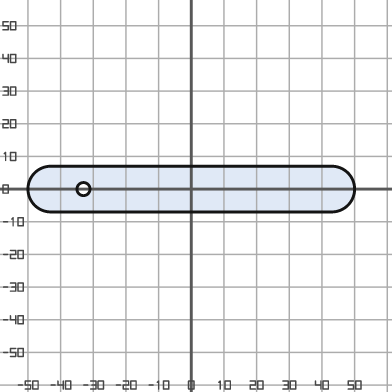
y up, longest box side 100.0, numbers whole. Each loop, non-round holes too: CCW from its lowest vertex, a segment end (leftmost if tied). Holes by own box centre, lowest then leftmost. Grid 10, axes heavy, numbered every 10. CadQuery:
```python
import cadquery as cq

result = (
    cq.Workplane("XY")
    .moveTo(-43.0, -7.0)
    .lineTo(43.0, -7.0)
    .threePointArc((50.0, 0.0), (43.0, 7.0))
    .lineTo(-43.0, 7.0)
    .threePointArc((-50.0, 0.0), (-43.0, -7.0))
    .close()
    .moveTo(-33.0, 0.0)
    .circle(2.0)
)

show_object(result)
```